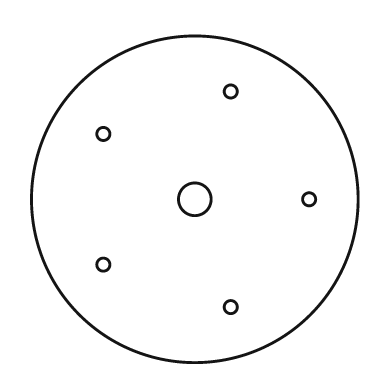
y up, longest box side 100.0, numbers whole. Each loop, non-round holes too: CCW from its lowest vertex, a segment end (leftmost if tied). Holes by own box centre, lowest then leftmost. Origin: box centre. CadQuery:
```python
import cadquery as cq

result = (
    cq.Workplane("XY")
    .moveTo(0.0, 0.0)
    .circle(50.0)
    .moveTo(11.0, -33.0)
    .circle(2.0)
    .moveTo(-28.0, -20.0)
    .circle(2.0)
    .moveTo(0.0, 0.0)
    .circle(5.0)
    .moveTo(35.0, 0.0)
    .circle(2.0)
    .moveTo(-28.0, 20.0)
    .circle(2.0)
    .moveTo(11.0, 33.0)
    .circle(2.0)
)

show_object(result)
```